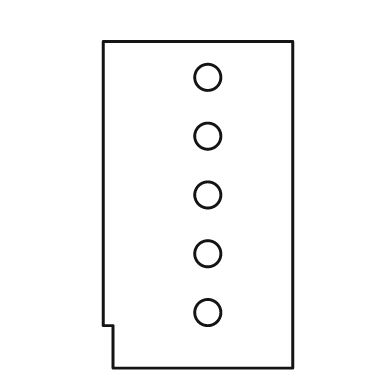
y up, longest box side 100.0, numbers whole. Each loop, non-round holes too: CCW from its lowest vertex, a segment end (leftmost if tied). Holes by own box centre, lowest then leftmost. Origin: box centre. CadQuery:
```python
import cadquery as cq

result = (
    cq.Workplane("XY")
    .moveTo(-26.0, -50.0)
    .lineTo(29.0, -50.0)
    .lineTo(29.0, 50.0)
    .lineTo(-29.0, 50.0)
    .lineTo(-29.0, -37.0)
    .lineTo(-26.0, -37.0)
    .close()
    .moveTo(3.0, -33.0)
    .circle(4.0)
    .moveTo(3.0, -15.0)
    .circle(4.0)
    .moveTo(3.0, 3.0)
    .circle(4.0)
    .moveTo(3.0, 21.0)
    .circle(4.0)
    .moveTo(3.0, 39.0)
    .circle(4.0)
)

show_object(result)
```